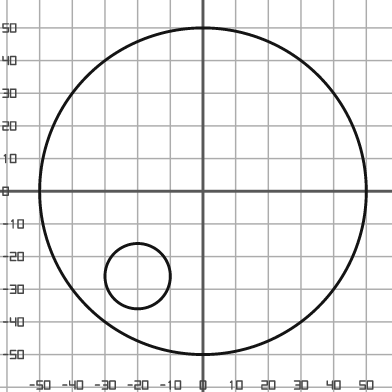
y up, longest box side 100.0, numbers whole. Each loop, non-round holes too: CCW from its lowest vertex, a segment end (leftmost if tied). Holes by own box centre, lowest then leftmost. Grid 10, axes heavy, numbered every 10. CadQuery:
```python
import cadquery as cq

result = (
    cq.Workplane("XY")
    .moveTo(0.0, 0.0)
    .circle(50.0)
    .moveTo(-20.0, -26.0)
    .circle(10.0)
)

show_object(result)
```